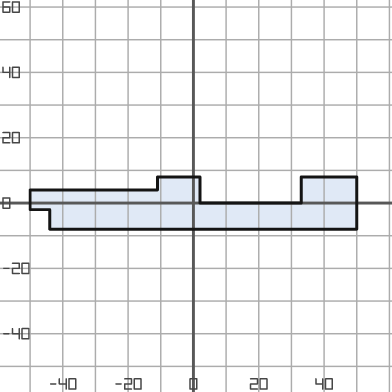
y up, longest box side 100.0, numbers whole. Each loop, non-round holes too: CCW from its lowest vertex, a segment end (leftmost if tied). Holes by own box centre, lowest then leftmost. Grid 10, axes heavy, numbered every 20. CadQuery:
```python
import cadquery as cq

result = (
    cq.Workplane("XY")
    .moveTo(-44.0, -8.0)
    .lineTo(50.0, -8.0)
    .lineTo(50.0, 8.0)
    .lineTo(33.0, 8.0)
    .lineTo(33.0, 0.0)
    .lineTo(2.0, 0.0)
    .lineTo(2.0, 8.0)
    .lineTo(-11.0, 8.0)
    .lineTo(-11.0, 4.0)
    .lineTo(-50.0, 4.0)
    .lineTo(-50.0, -2.0)
    .lineTo(-44.0, -2.0)
    .close()
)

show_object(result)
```